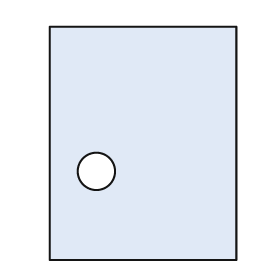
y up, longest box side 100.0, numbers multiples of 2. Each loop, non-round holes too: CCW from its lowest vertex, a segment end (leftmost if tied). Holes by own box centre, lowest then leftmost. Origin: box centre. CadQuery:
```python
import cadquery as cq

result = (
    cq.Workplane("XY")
    .moveTo(-40.0, -50.0)
    .lineTo(40.0, -50.0)
    .lineTo(40.0, 50.0)
    .lineTo(-40.0, 50.0)
    .close()
    .moveTo(-20.0, -12.0)
    .circle(8.0)
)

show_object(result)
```